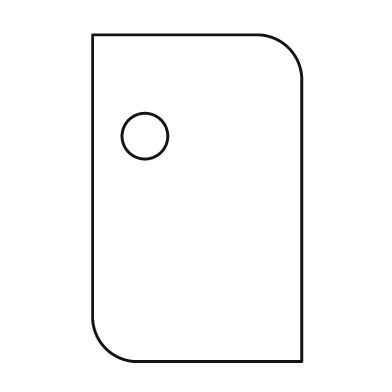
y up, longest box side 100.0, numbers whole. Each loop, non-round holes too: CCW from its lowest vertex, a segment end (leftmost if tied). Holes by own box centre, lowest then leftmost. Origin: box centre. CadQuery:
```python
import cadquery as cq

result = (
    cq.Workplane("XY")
    .moveTo(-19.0, -50.0)
    .lineTo(32.0, -50.0)
    .lineTo(32.0, 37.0)
    .threePointArc((28.0, 46.0), (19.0, 50.0))
    .lineTo(-32.0, 50.0)
    .lineTo(-32.0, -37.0)
    .threePointArc((-28.0, -46.0), (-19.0, -50.0))
    .close()
    .moveTo(-16.0, 19.0)
    .circle(7.0)
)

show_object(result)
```